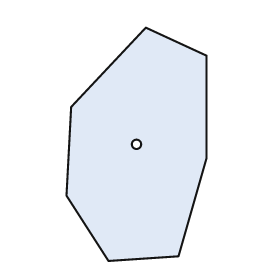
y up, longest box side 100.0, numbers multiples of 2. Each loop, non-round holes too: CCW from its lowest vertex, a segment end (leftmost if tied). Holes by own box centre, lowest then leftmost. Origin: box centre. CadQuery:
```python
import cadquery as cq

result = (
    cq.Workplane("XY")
    .moveTo(-12.0, -50.0)
    .lineTo(18.0, -48.0)
    .lineTo(30.0, -6.0)
    .lineTo(30.0, 38.0)
    .lineTo(4.0, 50.0)
    .lineTo(-28.0, 16.0)
    .lineTo(-30.0, -22.0)
    .close()
    .moveTo(0.0, 0.0)
    .circle(2.0)
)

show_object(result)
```